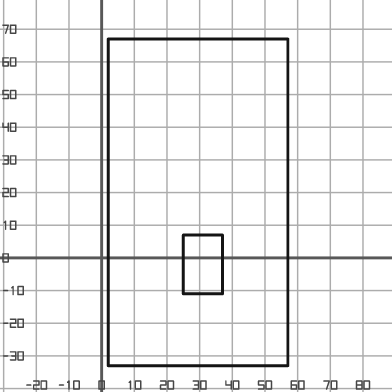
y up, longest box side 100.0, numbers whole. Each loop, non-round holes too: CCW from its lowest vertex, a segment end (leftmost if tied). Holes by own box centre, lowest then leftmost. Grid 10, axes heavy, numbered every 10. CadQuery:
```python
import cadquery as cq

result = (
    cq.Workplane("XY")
    .moveTo(2.0, -33.0)
    .lineTo(57.0, -33.0)
    .lineTo(57.0, 67.0)
    .lineTo(2.0, 67.0)
    .close()
    .moveTo(25.0, -11.0)
    .lineTo(37.0, -11.0)
    .lineTo(37.0, 7.0)
    .lineTo(25.0, 7.0)
    .close()
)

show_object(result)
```